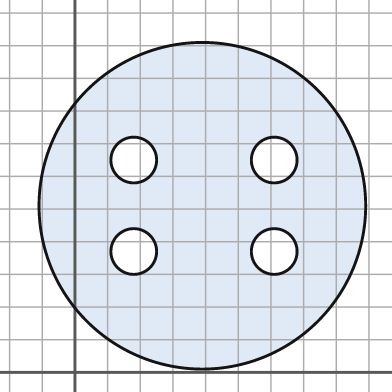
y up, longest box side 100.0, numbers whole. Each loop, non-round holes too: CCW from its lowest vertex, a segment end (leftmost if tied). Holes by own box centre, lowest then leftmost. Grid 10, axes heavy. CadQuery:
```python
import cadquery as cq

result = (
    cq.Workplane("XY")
    .moveTo(39.0, 51.0)
    .circle(50.0)
    .moveTo(18.0, 37.0)
    .circle(7.0)
    .moveTo(61.0, 37.0)
    .circle(7.0)
    .moveTo(18.0, 65.0)
    .circle(7.0)
    .moveTo(61.0, 65.0)
    .circle(7.0)
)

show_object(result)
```